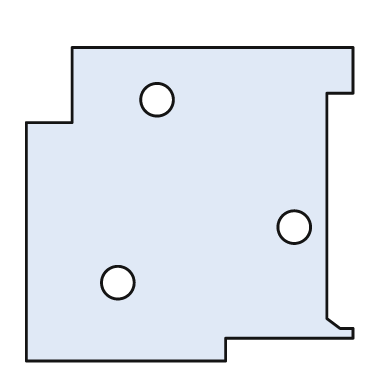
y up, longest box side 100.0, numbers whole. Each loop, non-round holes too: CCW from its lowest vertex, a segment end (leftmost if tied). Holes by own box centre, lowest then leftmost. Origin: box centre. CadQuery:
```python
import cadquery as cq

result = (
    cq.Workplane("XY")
    .moveTo(-50.0, -48.0)
    .lineTo(11.0, -48.0)
    .lineTo(11.0, -41.0)
    .lineTo(50.0, -41.0)
    .lineTo(50.0, -38.0)
    .lineTo(46.0, -38.0)
    .lineTo(42.0, -35.0)
    .lineTo(42.0, 34.0)
    .lineTo(50.0, 34.0)
    .lineTo(50.0, 48.0)
    .lineTo(-36.0, 48.0)
    .lineTo(-36.0, 25.0)
    .lineTo(-50.0, 25.0)
    .close()
    .moveTo(-22.0, -24.0)
    .circle(5.0)
    .moveTo(32.0, -7.0)
    .circle(5.0)
    .moveTo(-10.0, 32.0)
    .circle(5.0)
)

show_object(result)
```